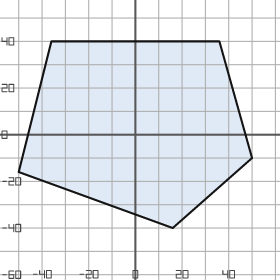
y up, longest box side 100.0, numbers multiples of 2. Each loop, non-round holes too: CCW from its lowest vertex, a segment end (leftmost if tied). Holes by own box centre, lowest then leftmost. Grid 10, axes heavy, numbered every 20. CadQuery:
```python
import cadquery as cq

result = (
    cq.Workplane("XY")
    .moveTo(16.0, -40.0)
    .lineTo(50.0, -10.0)
    .lineTo(36.0, 40.0)
    .lineTo(-36.0, 40.0)
    .lineTo(-50.0, -16.0)
    .close()
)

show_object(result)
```